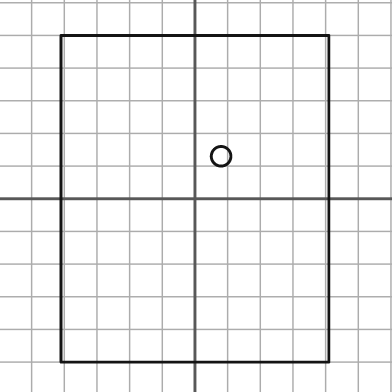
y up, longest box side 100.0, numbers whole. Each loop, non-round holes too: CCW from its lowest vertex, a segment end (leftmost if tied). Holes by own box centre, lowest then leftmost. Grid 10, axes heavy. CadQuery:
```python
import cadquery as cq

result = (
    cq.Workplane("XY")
    .moveTo(-41.0, -50.0)
    .lineTo(41.0, -50.0)
    .lineTo(41.0, 50.0)
    .lineTo(-41.0, 50.0)
    .close()
    .moveTo(8.0, 13.0)
    .circle(3.0)
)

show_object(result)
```